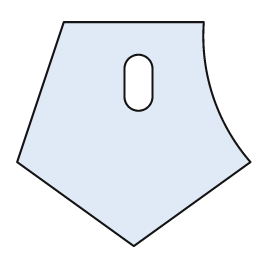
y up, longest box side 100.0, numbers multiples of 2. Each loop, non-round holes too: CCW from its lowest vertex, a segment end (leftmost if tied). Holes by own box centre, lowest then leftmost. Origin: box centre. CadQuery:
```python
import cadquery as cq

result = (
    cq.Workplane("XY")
    .moveTo(0.0, -48.0)
    .lineTo(50.0, -12.0)
    .threePointArc((34.0, 16.0), (30.0, 48.0))
    .lineTo(-30.0, 48.0)
    .lineTo(-50.0, -12.0)
    .close()
    .moveTo(-4.0, 16.0)
    .threePointArc((2.0, 10.0), (8.0, 16.0))
    .lineTo(8.0, 28.0)
    .threePointArc((2.0, 34.0), (-4.0, 28.0))
    .close()
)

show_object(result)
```